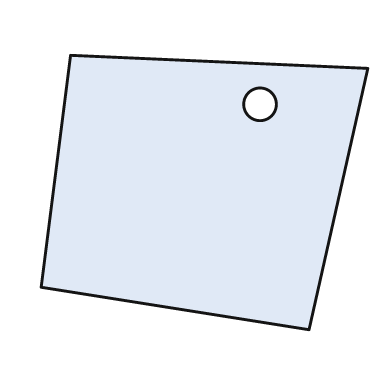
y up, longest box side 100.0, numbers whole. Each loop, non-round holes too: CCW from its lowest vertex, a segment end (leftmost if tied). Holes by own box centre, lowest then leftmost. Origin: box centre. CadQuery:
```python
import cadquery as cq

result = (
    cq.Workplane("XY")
    .moveTo(32.0, -42.0)
    .lineTo(50.0, 38.0)
    .lineTo(-41.0, 42.0)
    .lineTo(-50.0, -29.0)
    .close()
    .moveTo(17.0, 27.0)
    .circle(5.0)
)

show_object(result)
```